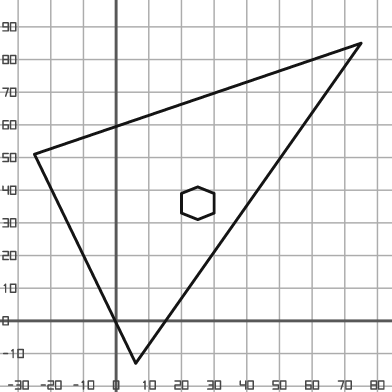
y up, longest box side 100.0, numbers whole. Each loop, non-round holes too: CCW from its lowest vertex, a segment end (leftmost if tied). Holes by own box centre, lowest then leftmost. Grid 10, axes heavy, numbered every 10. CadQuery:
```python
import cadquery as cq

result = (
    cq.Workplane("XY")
    .moveTo(6.0, -13.0)
    .lineTo(75.0, 85.0)
    .lineTo(-25.0, 51.0)
    .close()
    .moveTo(25.0, 31.0)
    .lineTo(30.0, 33.0)
    .lineTo(30.0, 39.0)
    .lineTo(25.0, 41.0)
    .lineTo(20.0, 39.0)
    .lineTo(20.0, 33.0)
    .close()
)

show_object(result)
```